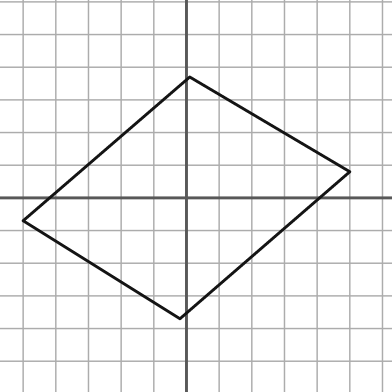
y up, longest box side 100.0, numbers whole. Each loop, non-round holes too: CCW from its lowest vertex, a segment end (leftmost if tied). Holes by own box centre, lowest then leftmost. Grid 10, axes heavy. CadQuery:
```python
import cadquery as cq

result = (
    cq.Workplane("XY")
    .moveTo(-2.0, -37.0)
    .lineTo(50.0, 8.0)
    .lineTo(1.0, 37.0)
    .lineTo(-50.0, -7.0)
    .close()
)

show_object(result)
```